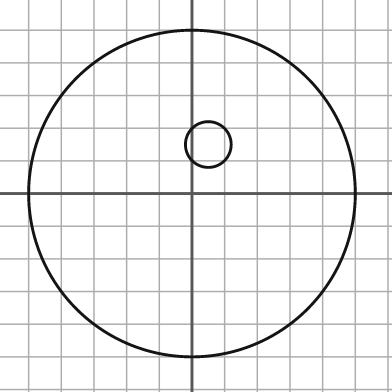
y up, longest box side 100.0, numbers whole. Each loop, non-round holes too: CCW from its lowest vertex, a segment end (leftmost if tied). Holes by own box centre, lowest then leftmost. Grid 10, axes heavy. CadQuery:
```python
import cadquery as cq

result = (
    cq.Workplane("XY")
    .moveTo(0.0, 0.0)
    .circle(50.0)
    .moveTo(5.0, 15.0)
    .circle(7.0)
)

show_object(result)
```